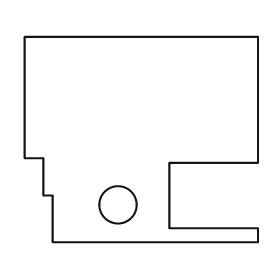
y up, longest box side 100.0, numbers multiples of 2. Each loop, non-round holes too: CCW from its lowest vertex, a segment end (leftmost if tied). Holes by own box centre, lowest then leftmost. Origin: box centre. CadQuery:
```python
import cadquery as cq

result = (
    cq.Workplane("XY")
    .moveTo(-38.0, -44.0)
    .lineTo(50.0, -44.0)
    .lineTo(50.0, -38.0)
    .lineTo(12.0, -38.0)
    .lineTo(12.0, -10.0)
    .lineTo(50.0, -10.0)
    .lineTo(50.0, 44.0)
    .lineTo(-50.0, 44.0)
    .lineTo(-50.0, -8.0)
    .lineTo(-42.0, -8.0)
    .lineTo(-42.0, -24.0)
    .lineTo(-38.0, -24.0)
    .close()
    .moveTo(-10.0, -28.0)
    .circle(8.0)
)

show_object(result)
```